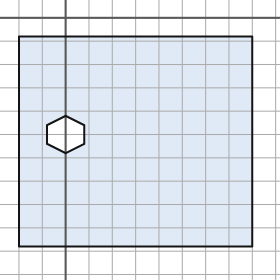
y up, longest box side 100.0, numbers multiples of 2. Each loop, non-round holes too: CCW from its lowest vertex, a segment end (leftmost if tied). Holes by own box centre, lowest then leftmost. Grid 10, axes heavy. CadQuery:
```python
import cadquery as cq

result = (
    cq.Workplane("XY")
    .moveTo(-20.0, -98.0)
    .lineTo(80.0, -98.0)
    .lineTo(80.0, -8.0)
    .lineTo(-20.0, -8.0)
    .close()
    .moveTo(0.0, -58.0)
    .lineTo(8.0, -54.0)
    .lineTo(8.0, -46.0)
    .lineTo(0.0, -42.0)
    .lineTo(-8.0, -46.0)
    .lineTo(-8.0, -54.0)
    .close()
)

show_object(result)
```